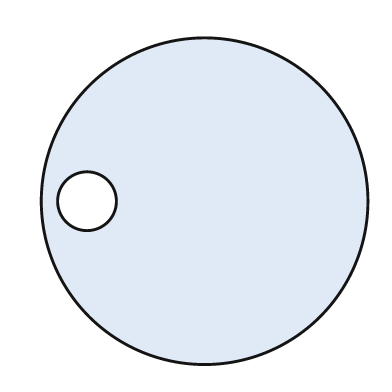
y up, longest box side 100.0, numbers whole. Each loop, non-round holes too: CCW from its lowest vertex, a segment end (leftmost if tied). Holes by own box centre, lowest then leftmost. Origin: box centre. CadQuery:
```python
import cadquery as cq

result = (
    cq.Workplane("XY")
    .moveTo(0.0, 0.0)
    .circle(50.0)
    .moveTo(-36.0, 0.0)
    .circle(9.0)
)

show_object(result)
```